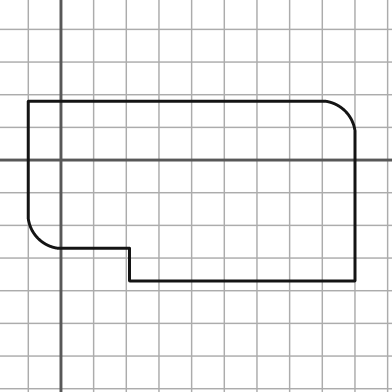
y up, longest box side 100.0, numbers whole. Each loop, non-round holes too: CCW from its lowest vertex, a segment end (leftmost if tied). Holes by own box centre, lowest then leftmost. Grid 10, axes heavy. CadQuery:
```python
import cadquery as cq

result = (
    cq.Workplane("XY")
    .moveTo(21.0, -37.0)
    .lineTo(90.0, -37.0)
    .lineTo(90.0, 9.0)
    .threePointArc((87.0, 15.0), (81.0, 18.0))
    .lineTo(-10.0, 18.0)
    .lineTo(-10.0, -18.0)
    .threePointArc((-7.0, -24.0), (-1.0, -27.0))
    .lineTo(21.0, -27.0)
    .close()
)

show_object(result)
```